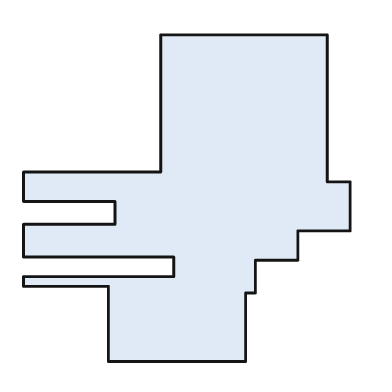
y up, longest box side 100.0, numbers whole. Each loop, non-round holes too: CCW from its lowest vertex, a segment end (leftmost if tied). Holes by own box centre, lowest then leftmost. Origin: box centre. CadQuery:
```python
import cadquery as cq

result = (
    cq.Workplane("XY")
    .moveTo(-24.0, -50.0)
    .lineTo(18.0, -50.0)
    .lineTo(18.0, -29.0)
    .lineTo(21.0, -29.0)
    .lineTo(21.0, -19.0)
    .lineTo(34.0, -19.0)
    .lineTo(34.0, -10.0)
    .lineTo(50.0, -10.0)
    .lineTo(50.0, 5.0)
    .lineTo(43.0, 5.0)
    .lineTo(43.0, 50.0)
    .lineTo(-8.0, 50.0)
    .lineTo(-8.0, 8.0)
    .lineTo(-50.0, 8.0)
    .lineTo(-50.0, -1.0)
    .lineTo(-22.0, -1.0)
    .lineTo(-22.0, -8.0)
    .lineTo(-50.0, -8.0)
    .lineTo(-50.0, -18.0)
    .lineTo(-4.0, -18.0)
    .lineTo(-4.0, -24.0)
    .lineTo(-50.0, -24.0)
    .lineTo(-50.0, -27.0)
    .lineTo(-24.0, -27.0)
    .close()
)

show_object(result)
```